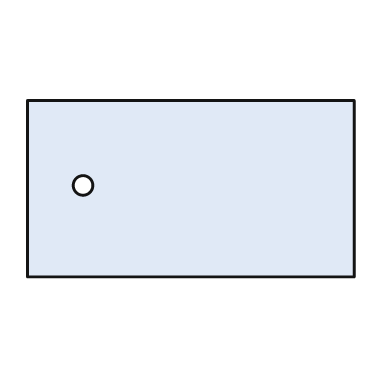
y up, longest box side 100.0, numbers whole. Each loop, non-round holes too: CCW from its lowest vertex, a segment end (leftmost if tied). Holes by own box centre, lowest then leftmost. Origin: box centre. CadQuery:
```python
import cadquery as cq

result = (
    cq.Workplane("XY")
    .moveTo(-50.0, -27.0)
    .lineTo(50.0, -27.0)
    .lineTo(50.0, 27.0)
    .lineTo(-50.0, 27.0)
    .close()
    .moveTo(-33.0, 1.0)
    .circle(3.0)
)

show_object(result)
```